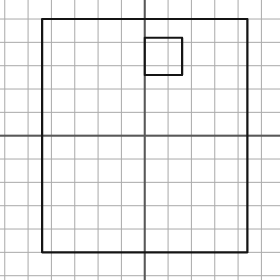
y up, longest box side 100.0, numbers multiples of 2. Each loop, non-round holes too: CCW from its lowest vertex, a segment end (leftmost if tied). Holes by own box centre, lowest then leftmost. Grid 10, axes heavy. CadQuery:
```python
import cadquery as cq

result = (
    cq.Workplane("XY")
    .moveTo(-44.0, -50.0)
    .lineTo(44.0, -50.0)
    .lineTo(44.0, 50.0)
    .lineTo(-44.0, 50.0)
    .close()
    .moveTo(0.0, 26.0)
    .lineTo(16.0, 26.0)
    .lineTo(16.0, 42.0)
    .lineTo(0.0, 42.0)
    .close()
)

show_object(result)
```